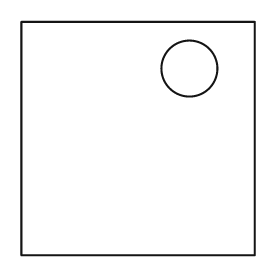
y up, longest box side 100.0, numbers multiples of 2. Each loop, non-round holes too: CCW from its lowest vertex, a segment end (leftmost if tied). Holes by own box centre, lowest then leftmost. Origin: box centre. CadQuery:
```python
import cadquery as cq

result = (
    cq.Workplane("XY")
    .moveTo(-50.0, -50.0)
    .lineTo(50.0, -50.0)
    .lineTo(50.0, 50.0)
    .lineTo(-50.0, 50.0)
    .close()
    .moveTo(22.0, 30.0)
    .circle(12.0)
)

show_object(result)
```